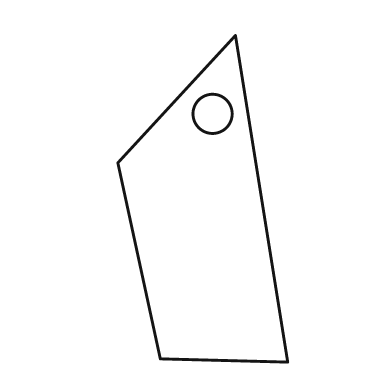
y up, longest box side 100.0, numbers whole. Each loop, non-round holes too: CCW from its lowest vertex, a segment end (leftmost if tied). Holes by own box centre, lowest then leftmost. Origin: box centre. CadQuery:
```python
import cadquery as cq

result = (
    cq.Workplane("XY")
    .moveTo(26.0, -50.0)
    .lineTo(10.0, 50.0)
    .lineTo(-26.0, 11.0)
    .lineTo(-13.0, -49.0)
    .close()
    .moveTo(3.0, 26.0)
    .circle(6.0)
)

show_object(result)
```